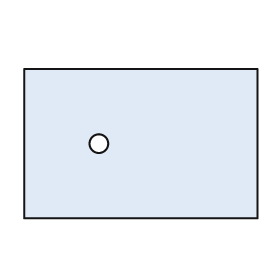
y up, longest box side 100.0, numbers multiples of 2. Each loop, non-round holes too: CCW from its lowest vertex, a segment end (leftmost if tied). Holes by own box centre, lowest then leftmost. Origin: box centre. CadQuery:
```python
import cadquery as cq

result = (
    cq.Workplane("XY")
    .moveTo(-50.0, -32.0)
    .lineTo(50.0, -32.0)
    .lineTo(50.0, 32.0)
    .lineTo(-50.0, 32.0)
    .close()
    .moveTo(-18.0, 0.0)
    .circle(4.0)
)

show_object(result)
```